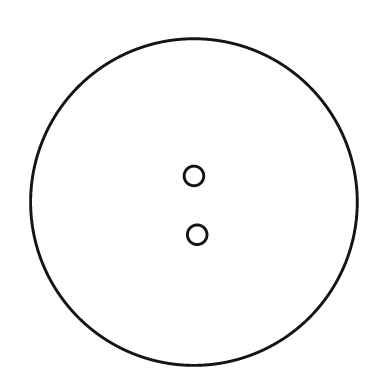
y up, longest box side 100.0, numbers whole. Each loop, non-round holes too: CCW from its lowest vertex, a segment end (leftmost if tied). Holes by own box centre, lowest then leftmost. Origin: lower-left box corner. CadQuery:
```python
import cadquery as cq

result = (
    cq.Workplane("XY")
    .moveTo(50.0, 50.0)
    .circle(50.0)
    .moveTo(51.0, 40.0)
    .circle(3.0)
    .moveTo(50.0, 58.0)
    .circle(3.0)
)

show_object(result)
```